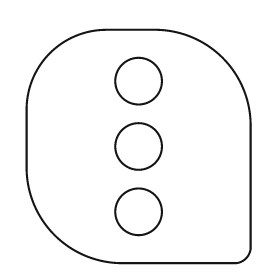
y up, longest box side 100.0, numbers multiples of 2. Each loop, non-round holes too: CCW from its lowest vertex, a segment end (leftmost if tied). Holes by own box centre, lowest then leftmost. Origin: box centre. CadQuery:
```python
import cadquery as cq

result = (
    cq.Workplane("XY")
    .moveTo(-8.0, -50.0)
    .lineTo(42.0, -50.0)
    .threePointArc((46.0, -48.0), (48.0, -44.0))
    .lineTo(48.0, 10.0)
    .threePointArc((36.0, 38.0), (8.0, 50.0))
    .lineTo(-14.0, 50.0)
    .threePointArc((-38.0, 40.0), (-48.0, 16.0))
    .lineTo(-48.0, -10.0)
    .threePointArc((-36.0, -38.0), (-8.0, -50.0))
    .close()
    .moveTo(0.0, -28.0)
    .circle(10.0)
    .moveTo(0.0, 0.0)
    .circle(10.0)
    .moveTo(0.0, 28.0)
    .circle(10.0)
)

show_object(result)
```